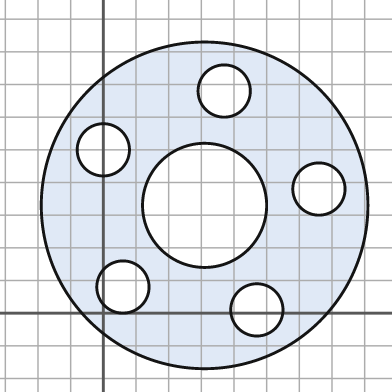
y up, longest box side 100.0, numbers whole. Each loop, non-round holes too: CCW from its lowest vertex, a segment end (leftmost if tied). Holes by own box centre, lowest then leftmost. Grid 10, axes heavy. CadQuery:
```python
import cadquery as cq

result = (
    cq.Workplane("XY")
    .moveTo(31.0, 33.0)
    .circle(50.0)
    .moveTo(47.0, 1.0)
    .circle(8.0)
    .moveTo(6.0, 8.0)
    .circle(8.0)
    .moveTo(31.0, 33.0)
    .circle(19.0)
    .moveTo(66.0, 38.0)
    .circle(8.0)
    .moveTo(0.0, 50.0)
    .circle(8.0)
    .moveTo(37.0, 68.0)
    .circle(8.0)
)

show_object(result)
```